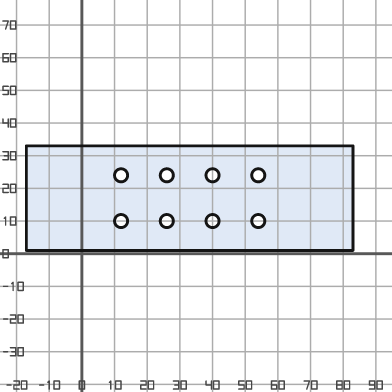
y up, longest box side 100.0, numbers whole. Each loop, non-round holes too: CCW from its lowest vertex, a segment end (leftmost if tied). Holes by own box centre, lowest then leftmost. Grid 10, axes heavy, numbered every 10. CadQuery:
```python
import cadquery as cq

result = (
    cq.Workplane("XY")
    .moveTo(-17.0, 1.0)
    .lineTo(83.0, 1.0)
    .lineTo(83.0, 33.0)
    .lineTo(-17.0, 33.0)
    .close()
    .moveTo(12.0, 10.0)
    .circle(2.0)
    .moveTo(26.0, 10.0)
    .circle(2.0)
    .moveTo(40.0, 10.0)
    .circle(2.0)
    .moveTo(54.0, 10.0)
    .circle(2.0)
    .moveTo(12.0, 24.0)
    .circle(2.0)
    .moveTo(26.0, 24.0)
    .circle(2.0)
    .moveTo(40.0, 24.0)
    .circle(2.0)
    .moveTo(54.0, 24.0)
    .circle(2.0)
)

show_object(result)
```